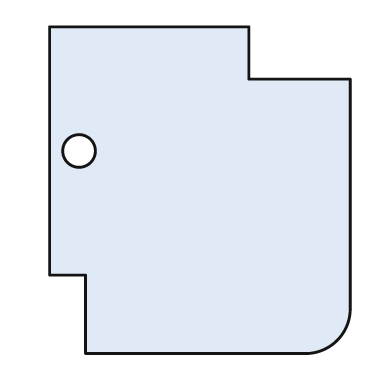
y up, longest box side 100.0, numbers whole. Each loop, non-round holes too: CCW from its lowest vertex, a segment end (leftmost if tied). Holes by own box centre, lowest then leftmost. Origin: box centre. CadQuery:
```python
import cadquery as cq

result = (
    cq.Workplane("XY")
    .moveTo(-35.0, -50.0)
    .lineTo(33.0, -50.0)
    .threePointArc((42.0, -46.0), (46.0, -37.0))
    .lineTo(46.0, 34.0)
    .lineTo(15.0, 34.0)
    .lineTo(15.0, 50.0)
    .lineTo(-46.0, 50.0)
    .lineTo(-46.0, -26.0)
    .lineTo(-35.0, -26.0)
    .close()
    .moveTo(-37.0, 12.0)
    .circle(5.0)
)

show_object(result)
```